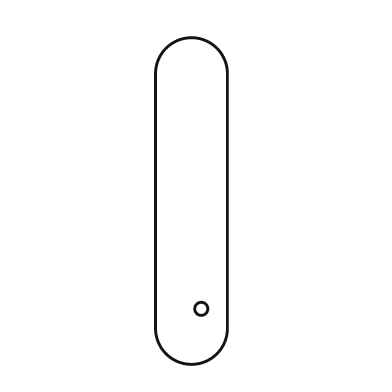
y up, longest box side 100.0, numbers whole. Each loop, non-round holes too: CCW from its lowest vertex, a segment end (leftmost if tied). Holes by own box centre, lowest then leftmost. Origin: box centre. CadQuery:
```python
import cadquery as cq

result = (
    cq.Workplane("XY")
    .moveTo(-11.0, -39.0)
    .threePointArc((0.0, -50.0), (11.0, -39.0))
    .lineTo(11.0, 39.0)
    .threePointArc((0.0, 50.0), (-11.0, 39.0))
    .close()
    .moveTo(3.0, -33.0)
    .circle(2.0)
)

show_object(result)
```